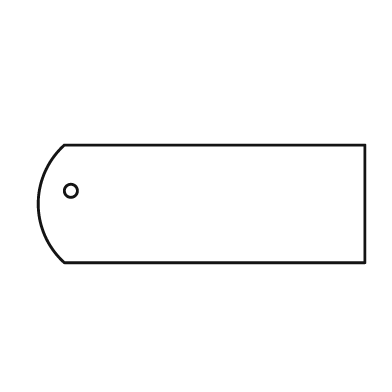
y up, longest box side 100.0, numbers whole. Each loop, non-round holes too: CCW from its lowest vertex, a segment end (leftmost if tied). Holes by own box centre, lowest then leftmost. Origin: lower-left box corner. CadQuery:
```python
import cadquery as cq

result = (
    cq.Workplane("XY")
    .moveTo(8.0, 0.0)
    .lineTo(100.0, 0.0)
    .lineTo(100.0, 36.0)
    .lineTo(8.0, 36.0)
    .threePointArc((0.0, 18.0), (8.0, 0.0))
    .close()
    .moveTo(10.0, 22.0)
    .circle(2.0)
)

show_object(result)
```